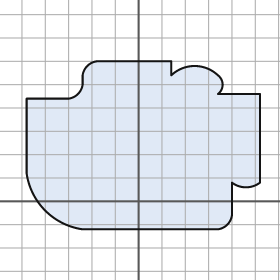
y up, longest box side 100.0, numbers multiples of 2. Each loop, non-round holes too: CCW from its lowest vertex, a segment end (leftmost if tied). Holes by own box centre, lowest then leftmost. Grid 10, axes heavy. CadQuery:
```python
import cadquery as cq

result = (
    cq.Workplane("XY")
    .moveTo(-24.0, -12.0)
    .lineTo(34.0, -12.0)
    .threePointArc((38.0, -10.0), (40.0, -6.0))
    .lineTo(40.0, 8.0)
    .threePointArc((46.0, 6.0), (52.0, 8.0))
    .lineTo(52.0, 46.0)
    .lineTo(34.0, 46.0)
    .threePointArc((36.0, 50.0), (34.0, 54.0))
    .threePointArc((24.0, 58.0), (14.0, 54.0))
    .lineTo(14.0, 60.0)
    .lineTo(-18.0, 60.0)
    .threePointArc((-22.0, 58.0), (-24.0, 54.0))
    .lineTo(-24.0, 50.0)
    .threePointArc((-26.0, 46.0), (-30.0, 44.0))
    .lineTo(-48.0, 44.0)
    .lineTo(-48.0, 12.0)
    .threePointArc((-40.0, -4.0), (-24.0, -12.0))
    .close()
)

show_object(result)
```